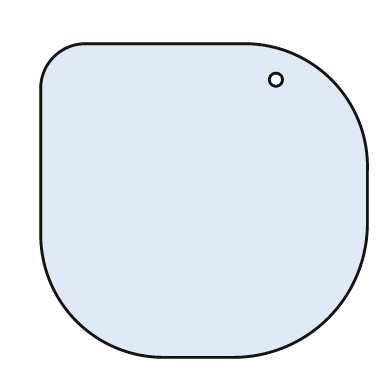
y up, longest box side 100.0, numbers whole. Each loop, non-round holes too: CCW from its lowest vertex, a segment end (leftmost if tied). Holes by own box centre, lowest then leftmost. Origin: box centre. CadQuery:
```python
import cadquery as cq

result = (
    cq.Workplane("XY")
    .moveTo(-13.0, -48.0)
    .lineTo(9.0, -48.0)
    .threePointArc((38.0, -36.0), (50.0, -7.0))
    .lineTo(50.0, 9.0)
    .threePointArc((39.0, 37.0), (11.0, 48.0))
    .lineTo(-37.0, 48.0)
    .threePointArc((-46.0, 44.0), (-50.0, 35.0))
    .lineTo(-50.0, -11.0)
    .threePointArc((-39.0, -37.0), (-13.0, -48.0))
    .close()
    .moveTo(22.0, 37.0)
    .circle(2.0)
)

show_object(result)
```